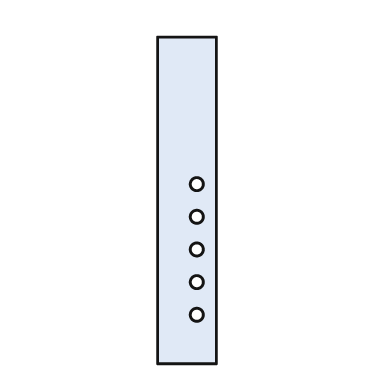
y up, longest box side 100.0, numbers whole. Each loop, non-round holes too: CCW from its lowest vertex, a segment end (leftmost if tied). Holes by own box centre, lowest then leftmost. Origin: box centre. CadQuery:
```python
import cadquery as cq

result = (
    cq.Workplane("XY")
    .moveTo(-9.0, -50.0)
    .lineTo(9.0, -50.0)
    .lineTo(9.0, 50.0)
    .lineTo(-9.0, 50.0)
    .close()
    .moveTo(3.0, -35.0)
    .circle(2.0)
    .moveTo(3.0, -25.0)
    .circle(2.0)
    .moveTo(3.0, -15.0)
    .circle(2.0)
    .moveTo(3.0, -5.0)
    .circle(2.0)
    .moveTo(3.0, 5.0)
    .circle(2.0)
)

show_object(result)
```